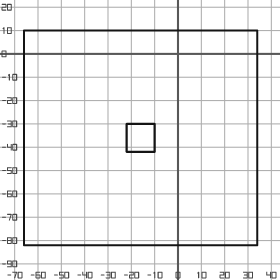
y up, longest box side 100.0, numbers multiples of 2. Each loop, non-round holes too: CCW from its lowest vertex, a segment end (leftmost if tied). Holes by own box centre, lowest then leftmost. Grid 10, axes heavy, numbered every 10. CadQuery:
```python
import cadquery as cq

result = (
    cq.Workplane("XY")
    .moveTo(-66.0, -82.0)
    .lineTo(34.0, -82.0)
    .lineTo(34.0, 10.0)
    .lineTo(-66.0, 10.0)
    .close()
    .moveTo(-22.0, -42.0)
    .lineTo(-10.0, -42.0)
    .lineTo(-10.0, -30.0)
    .lineTo(-22.0, -30.0)
    .close()
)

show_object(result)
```